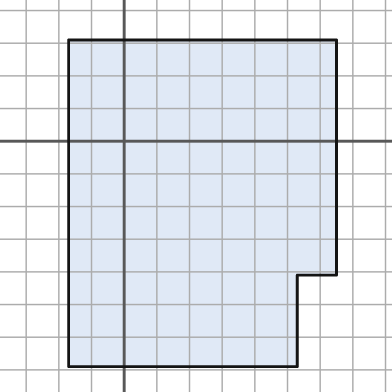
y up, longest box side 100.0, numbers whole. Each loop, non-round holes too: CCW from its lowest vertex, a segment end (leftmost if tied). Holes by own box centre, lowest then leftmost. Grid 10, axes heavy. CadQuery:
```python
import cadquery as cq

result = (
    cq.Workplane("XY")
    .moveTo(-17.0, -69.0)
    .lineTo(53.0, -69.0)
    .lineTo(53.0, -41.0)
    .lineTo(65.0, -41.0)
    .lineTo(65.0, 31.0)
    .lineTo(-17.0, 31.0)
    .close()
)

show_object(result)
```